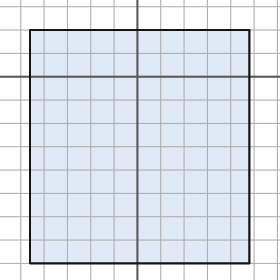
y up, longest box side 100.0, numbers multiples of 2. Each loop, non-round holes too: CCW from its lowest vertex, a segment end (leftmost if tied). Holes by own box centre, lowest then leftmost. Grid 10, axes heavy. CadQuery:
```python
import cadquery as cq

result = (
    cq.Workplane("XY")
    .moveTo(-46.0, -80.0)
    .lineTo(48.0, -80.0)
    .lineTo(48.0, 20.0)
    .lineTo(-46.0, 20.0)
    .close()
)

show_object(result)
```